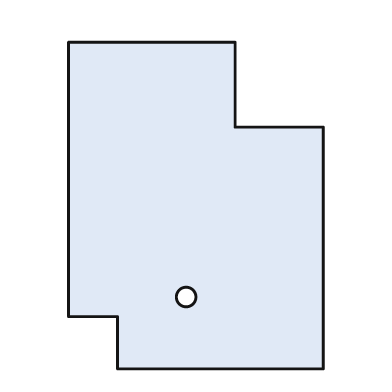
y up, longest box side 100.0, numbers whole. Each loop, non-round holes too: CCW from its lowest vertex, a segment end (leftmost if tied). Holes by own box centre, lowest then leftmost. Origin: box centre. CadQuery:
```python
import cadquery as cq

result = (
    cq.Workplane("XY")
    .moveTo(-24.0, -50.0)
    .lineTo(39.0, -50.0)
    .lineTo(39.0, 24.0)
    .lineTo(12.0, 24.0)
    .lineTo(12.0, 50.0)
    .lineTo(-39.0, 50.0)
    .lineTo(-39.0, -34.0)
    .lineTo(-24.0, -34.0)
    .close()
    .moveTo(-3.0, -28.0)
    .circle(3.0)
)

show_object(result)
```